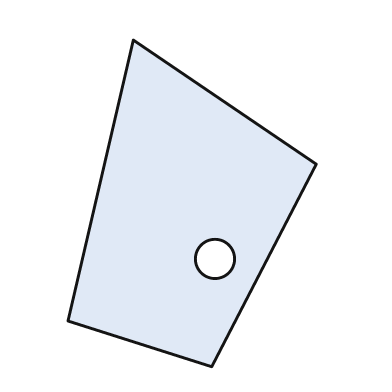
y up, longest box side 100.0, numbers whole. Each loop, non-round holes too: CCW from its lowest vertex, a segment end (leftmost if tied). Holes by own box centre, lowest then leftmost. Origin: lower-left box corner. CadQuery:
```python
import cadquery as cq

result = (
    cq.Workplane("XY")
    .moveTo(44.0, 0.0)
    .lineTo(76.0, 62.0)
    .lineTo(20.0, 100.0)
    .lineTo(0.0, 14.0)
    .close()
    .moveTo(45.0, 33.0)
    .circle(6.0)
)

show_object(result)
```